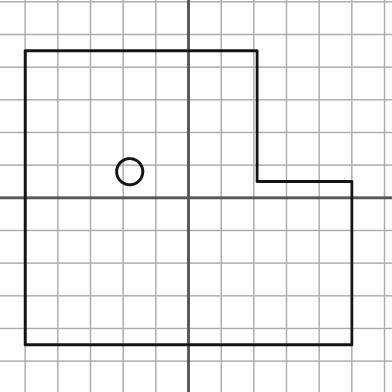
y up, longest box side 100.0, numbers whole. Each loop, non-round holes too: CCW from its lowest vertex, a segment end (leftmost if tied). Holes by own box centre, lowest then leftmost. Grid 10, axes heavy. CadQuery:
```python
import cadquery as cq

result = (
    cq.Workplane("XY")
    .moveTo(-50.0, -45.0)
    .lineTo(50.0, -45.0)
    .lineTo(50.0, 5.0)
    .lineTo(21.0, 5.0)
    .lineTo(21.0, 45.0)
    .lineTo(-50.0, 45.0)
    .close()
    .moveTo(-18.0, 8.0)
    .circle(4.0)
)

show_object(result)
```